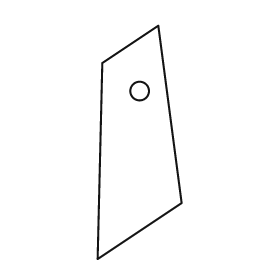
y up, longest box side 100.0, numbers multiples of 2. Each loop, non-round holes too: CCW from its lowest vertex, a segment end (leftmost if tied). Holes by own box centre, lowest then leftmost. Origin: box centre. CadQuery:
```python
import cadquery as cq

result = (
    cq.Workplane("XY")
    .moveTo(-18.0, -50.0)
    .lineTo(18.0, -26.0)
    .lineTo(8.0, 50.0)
    .lineTo(-16.0, 34.0)
    .close()
    .moveTo(0.0, 22.0)
    .circle(4.0)
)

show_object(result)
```